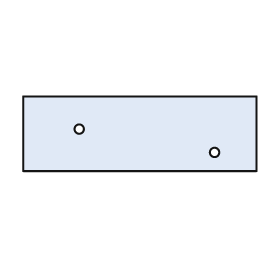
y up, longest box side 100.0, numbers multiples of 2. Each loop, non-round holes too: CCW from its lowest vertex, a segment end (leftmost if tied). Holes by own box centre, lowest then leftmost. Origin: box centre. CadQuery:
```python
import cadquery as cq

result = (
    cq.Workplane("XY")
    .moveTo(-50.0, -16.0)
    .lineTo(50.0, -16.0)
    .lineTo(50.0, 16.0)
    .lineTo(-50.0, 16.0)
    .close()
    .moveTo(32.0, -8.0)
    .circle(2.0)
    .moveTo(-26.0, 2.0)
    .circle(2.0)
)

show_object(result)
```